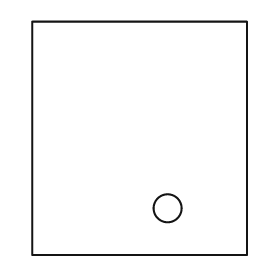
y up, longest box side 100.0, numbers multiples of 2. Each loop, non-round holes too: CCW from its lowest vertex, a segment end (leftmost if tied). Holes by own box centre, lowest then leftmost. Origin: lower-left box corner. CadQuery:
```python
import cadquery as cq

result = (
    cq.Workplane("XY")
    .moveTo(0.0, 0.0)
    .lineTo(92.0, 0.0)
    .lineTo(92.0, 100.0)
    .lineTo(0.0, 100.0)
    .close()
    .moveTo(58.0, 20.0)
    .circle(6.0)
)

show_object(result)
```